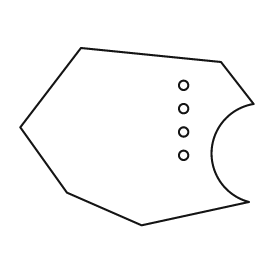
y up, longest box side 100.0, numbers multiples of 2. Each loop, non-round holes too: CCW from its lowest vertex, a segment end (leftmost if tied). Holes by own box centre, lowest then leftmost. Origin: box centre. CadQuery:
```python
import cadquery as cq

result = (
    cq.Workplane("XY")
    .moveTo(2.0, -38.0)
    .lineTo(48.0, -28.0)
    .threePointArc((32.0, -6.0), (50.0, 14.0))
    .lineTo(36.0, 32.0)
    .lineTo(-24.0, 38.0)
    .lineTo(-50.0, 4.0)
    .lineTo(-30.0, -24.0)
    .close()
    .moveTo(20.0, -8.0)
    .circle(2.0)
    .moveTo(20.0, 2.0)
    .circle(2.0)
    .moveTo(20.0, 12.0)
    .circle(2.0)
    .moveTo(20.0, 22.0)
    .circle(2.0)
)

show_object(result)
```